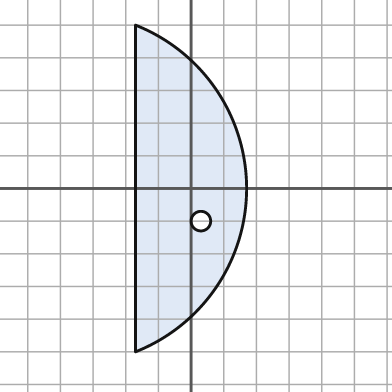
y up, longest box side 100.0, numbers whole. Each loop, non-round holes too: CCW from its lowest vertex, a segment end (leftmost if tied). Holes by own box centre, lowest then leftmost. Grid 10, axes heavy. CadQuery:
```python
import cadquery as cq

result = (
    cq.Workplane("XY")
    .moveTo(-17.0, -50.0)
    .threePointArc((17.0, 0.0), (-17.0, 50.0))
    .close()
    .moveTo(3.0, -10.0)
    .circle(3.0)
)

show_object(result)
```